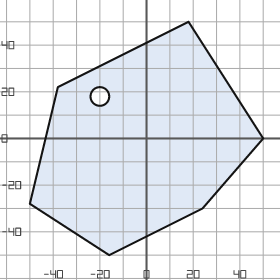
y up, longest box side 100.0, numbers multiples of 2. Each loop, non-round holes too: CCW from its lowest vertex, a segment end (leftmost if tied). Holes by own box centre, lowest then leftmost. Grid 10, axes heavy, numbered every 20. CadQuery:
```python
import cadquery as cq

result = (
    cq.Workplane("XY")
    .moveTo(-16.0, -50.0)
    .lineTo(24.0, -30.0)
    .lineTo(50.0, 0.0)
    .lineTo(18.0, 50.0)
    .lineTo(-38.0, 22.0)
    .lineTo(-50.0, -28.0)
    .close()
    .moveTo(-20.0, 18.0)
    .circle(4.0)
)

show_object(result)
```